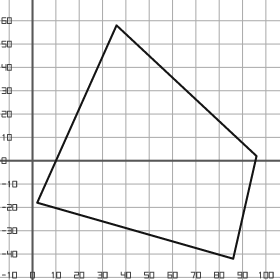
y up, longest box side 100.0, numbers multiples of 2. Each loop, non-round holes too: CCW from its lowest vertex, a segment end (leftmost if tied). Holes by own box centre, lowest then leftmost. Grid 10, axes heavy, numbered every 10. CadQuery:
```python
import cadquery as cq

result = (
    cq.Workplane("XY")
    .moveTo(86.0, -42.0)
    .lineTo(96.0, 2.0)
    .lineTo(36.0, 58.0)
    .lineTo(2.0, -18.0)
    .close()
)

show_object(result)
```